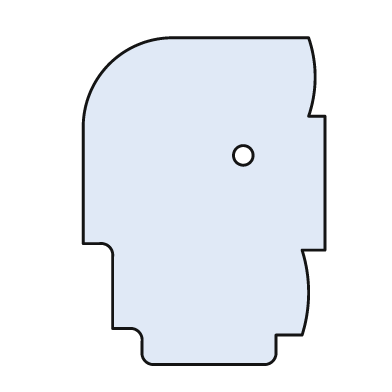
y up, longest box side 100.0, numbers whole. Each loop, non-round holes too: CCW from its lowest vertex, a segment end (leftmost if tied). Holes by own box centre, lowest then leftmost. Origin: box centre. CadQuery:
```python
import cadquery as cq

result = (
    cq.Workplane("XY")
    .moveTo(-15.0, -50.0)
    .lineTo(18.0, -50.0)
    .threePointArc((21.0, -49.0), (22.0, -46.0))
    .lineTo(22.0, -41.0)
    .lineTo(30.0, -41.0)
    .threePointArc((32.0, -28.0), (30.0, -15.0))
    .lineTo(37.0, -15.0)
    .lineTo(37.0, 26.0)
    .lineTo(32.0, 26.0)
    .threePointArc((34.0, 38.0), (32.0, 50.0))
    .lineTo(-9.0, 50.0)
    .threePointArc((-29.0, 42.0), (-37.0, 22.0))
    .lineTo(-37.0, -13.0)
    .lineTo(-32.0, -13.0)
    .threePointArc((-29.0, -14.0), (-28.0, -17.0))
    .lineTo(-28.0, -39.0)
    .lineTo(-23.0, -39.0)
    .threePointArc((-20.0, -40.0), (-19.0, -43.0))
    .lineTo(-19.0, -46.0)
    .threePointArc((-18.0, -49.0), (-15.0, -50.0))
    .close()
    .moveTo(12.0, 14.0)
    .circle(3.0)
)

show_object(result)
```